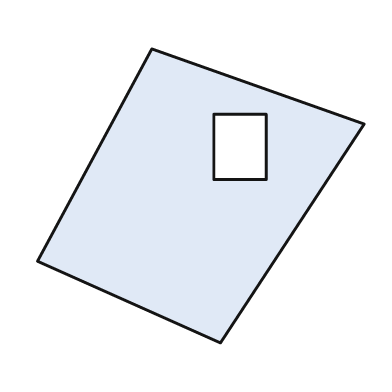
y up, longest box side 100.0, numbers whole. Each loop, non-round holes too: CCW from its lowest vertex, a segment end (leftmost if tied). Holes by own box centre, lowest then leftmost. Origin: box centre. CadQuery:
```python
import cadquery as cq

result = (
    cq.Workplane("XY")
    .moveTo(6.0, -45.0)
    .lineTo(50.0, 22.0)
    .lineTo(-15.0, 45.0)
    .lineTo(-50.0, -20.0)
    .close()
    .moveTo(4.0, 5.0)
    .lineTo(20.0, 5.0)
    .lineTo(20.0, 25.0)
    .lineTo(4.0, 25.0)
    .close()
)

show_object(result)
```